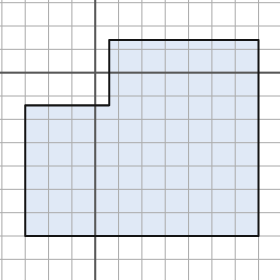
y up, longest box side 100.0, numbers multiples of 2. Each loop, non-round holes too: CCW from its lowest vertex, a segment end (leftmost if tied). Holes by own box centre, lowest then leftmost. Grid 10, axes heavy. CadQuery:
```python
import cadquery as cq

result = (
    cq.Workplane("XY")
    .moveTo(-30.0, -70.0)
    .lineTo(70.0, -70.0)
    .lineTo(70.0, 14.0)
    .lineTo(6.0, 14.0)
    .lineTo(6.0, -14.0)
    .lineTo(-30.0, -14.0)
    .close()
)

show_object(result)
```